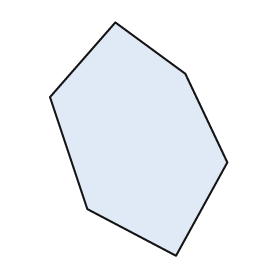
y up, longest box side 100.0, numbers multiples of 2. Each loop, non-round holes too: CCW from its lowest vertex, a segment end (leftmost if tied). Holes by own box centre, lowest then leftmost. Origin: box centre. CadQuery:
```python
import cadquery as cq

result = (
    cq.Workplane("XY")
    .moveTo(16.0, -50.0)
    .lineTo(38.0, -10.0)
    .lineTo(20.0, 28.0)
    .lineTo(-10.0, 50.0)
    .lineTo(-38.0, 18.0)
    .lineTo(-22.0, -30.0)
    .close()
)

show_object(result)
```